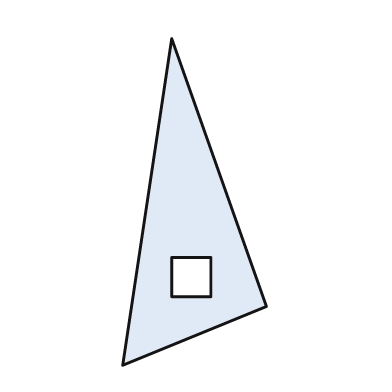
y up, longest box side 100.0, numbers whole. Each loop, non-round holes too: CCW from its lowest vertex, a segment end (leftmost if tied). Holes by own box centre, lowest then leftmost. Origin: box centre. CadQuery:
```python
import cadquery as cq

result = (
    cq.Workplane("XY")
    .moveTo(-22.0, -50.0)
    .lineTo(22.0, -32.0)
    .lineTo(-7.0, 50.0)
    .close()
    .moveTo(-7.0, -29.0)
    .lineTo(5.0, -29.0)
    .lineTo(5.0, -17.0)
    .lineTo(-7.0, -17.0)
    .close()
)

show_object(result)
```